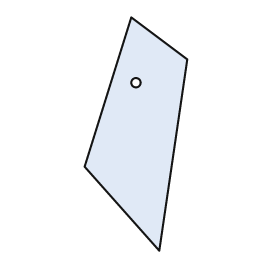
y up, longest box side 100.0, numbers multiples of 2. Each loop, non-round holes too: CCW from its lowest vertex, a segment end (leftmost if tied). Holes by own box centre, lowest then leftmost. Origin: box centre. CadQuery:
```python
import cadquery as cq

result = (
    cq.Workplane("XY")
    .moveTo(10.0, -50.0)
    .lineTo(22.0, 32.0)
    .lineTo(-2.0, 50.0)
    .lineTo(-22.0, -14.0)
    .close()
    .moveTo(0.0, 22.0)
    .circle(2.0)
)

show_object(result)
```